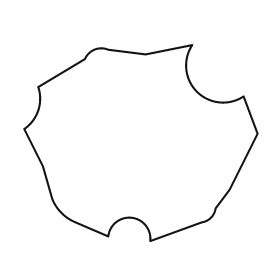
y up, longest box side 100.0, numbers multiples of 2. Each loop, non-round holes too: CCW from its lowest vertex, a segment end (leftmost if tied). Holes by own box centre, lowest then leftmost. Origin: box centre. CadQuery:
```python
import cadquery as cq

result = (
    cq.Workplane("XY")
    .moveTo(4.0, -42.0)
    .lineTo(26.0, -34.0)
    .threePointArc((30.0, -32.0), (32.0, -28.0))
    .lineTo(38.0, -20.0)
    .lineTo(50.0, 4.0)
    .lineTo(44.0, 20.0)
    .threePointArc((24.0, 22.0), (22.0, 42.0))
    .lineTo(2.0, 38.0)
    .lineTo(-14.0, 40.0)
    .threePointArc((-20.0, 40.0), (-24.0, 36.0))
    .lineTo(-44.0, 24.0)
    .threePointArc((-44.0, 14.0), (-50.0, 6.0))
    .lineTo(-42.0, -10.0)
    .lineTo(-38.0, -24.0)
    .threePointArc((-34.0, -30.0), (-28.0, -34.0))
    .lineTo(-14.0, -40.0)
    .threePointArc((-4.0, -32.0), (4.0, -42.0))
    .close()
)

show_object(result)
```